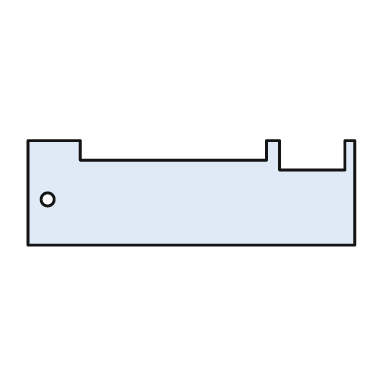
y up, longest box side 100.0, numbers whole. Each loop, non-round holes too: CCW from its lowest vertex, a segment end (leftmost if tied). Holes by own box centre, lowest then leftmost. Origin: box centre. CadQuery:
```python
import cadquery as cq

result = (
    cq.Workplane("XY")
    .moveTo(-50.0, -16.0)
    .lineTo(50.0, -16.0)
    .lineTo(50.0, 16.0)
    .lineTo(47.0, 16.0)
    .lineTo(47.0, 7.0)
    .lineTo(27.0, 7.0)
    .lineTo(27.0, 16.0)
    .lineTo(23.0, 16.0)
    .lineTo(23.0, 10.0)
    .lineTo(-34.0, 10.0)
    .lineTo(-34.0, 16.0)
    .lineTo(-50.0, 16.0)
    .close()
    .moveTo(-44.0, -2.0)
    .circle(2.0)
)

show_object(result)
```